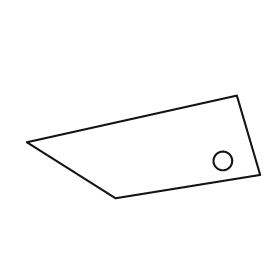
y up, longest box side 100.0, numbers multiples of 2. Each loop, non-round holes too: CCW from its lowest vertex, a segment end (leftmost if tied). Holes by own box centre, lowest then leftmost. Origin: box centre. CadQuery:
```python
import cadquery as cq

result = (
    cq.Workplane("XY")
    .moveTo(-12.0, -22.0)
    .lineTo(50.0, -12.0)
    .lineTo(40.0, 22.0)
    .lineTo(-50.0, 2.0)
    .close()
    .moveTo(34.0, -6.0)
    .circle(4.0)
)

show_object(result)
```